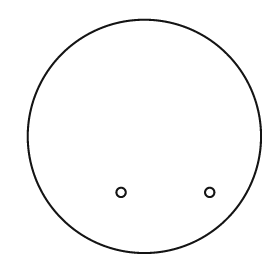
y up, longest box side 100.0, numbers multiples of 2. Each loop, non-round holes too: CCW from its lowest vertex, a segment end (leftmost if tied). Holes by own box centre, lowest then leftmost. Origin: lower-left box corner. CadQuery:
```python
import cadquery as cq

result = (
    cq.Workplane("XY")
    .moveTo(50.0, 50.0)
    .circle(50.0)
    .moveTo(40.0, 26.0)
    .circle(2.0)
    .moveTo(78.0, 26.0)
    .circle(2.0)
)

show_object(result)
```